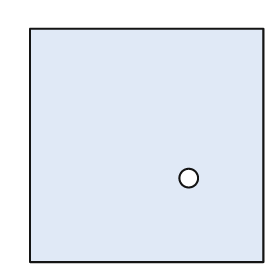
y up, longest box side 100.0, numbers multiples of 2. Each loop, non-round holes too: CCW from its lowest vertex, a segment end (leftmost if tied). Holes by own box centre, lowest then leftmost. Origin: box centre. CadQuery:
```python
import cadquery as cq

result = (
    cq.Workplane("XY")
    .moveTo(-50.0, -50.0)
    .lineTo(50.0, -50.0)
    .lineTo(50.0, 50.0)
    .lineTo(-50.0, 50.0)
    .close()
    .moveTo(18.0, -14.0)
    .circle(4.0)
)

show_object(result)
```